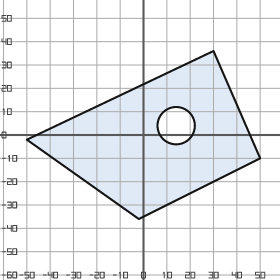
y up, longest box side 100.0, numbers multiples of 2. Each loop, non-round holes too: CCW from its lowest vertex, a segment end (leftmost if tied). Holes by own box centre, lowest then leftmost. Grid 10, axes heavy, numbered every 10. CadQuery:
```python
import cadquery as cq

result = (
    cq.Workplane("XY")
    .moveTo(-2.0, -36.0)
    .lineTo(50.0, -10.0)
    .lineTo(30.0, 36.0)
    .lineTo(-50.0, -2.0)
    .close()
    .moveTo(14.0, 4.0)
    .circle(8.0)
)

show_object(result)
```